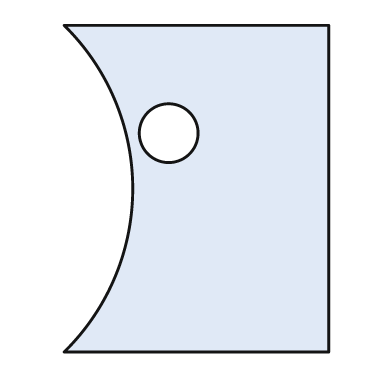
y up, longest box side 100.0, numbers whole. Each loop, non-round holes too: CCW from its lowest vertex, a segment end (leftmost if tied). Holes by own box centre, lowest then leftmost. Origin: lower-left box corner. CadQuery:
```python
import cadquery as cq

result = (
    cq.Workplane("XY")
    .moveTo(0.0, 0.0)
    .lineTo(81.0, 0.0)
    .lineTo(81.0, 100.0)
    .lineTo(0.0, 100.0)
    .threePointArc((21.0, 50.0), (0.0, 0.0))
    .close()
    .moveTo(32.0, 67.0)
    .circle(9.0)
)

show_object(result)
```